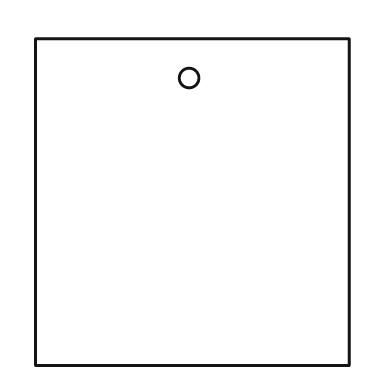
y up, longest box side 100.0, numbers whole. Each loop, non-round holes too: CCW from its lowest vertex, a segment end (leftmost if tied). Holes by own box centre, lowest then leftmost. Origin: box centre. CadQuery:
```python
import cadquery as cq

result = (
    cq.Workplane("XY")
    .moveTo(-48.0, -50.0)
    .lineTo(48.0, -50.0)
    .lineTo(48.0, 50.0)
    .lineTo(-48.0, 50.0)
    .close()
    .moveTo(-1.0, 38.0)
    .circle(3.0)
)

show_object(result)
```